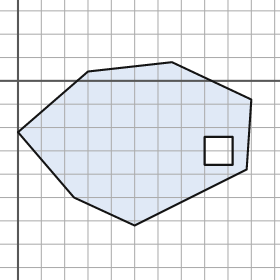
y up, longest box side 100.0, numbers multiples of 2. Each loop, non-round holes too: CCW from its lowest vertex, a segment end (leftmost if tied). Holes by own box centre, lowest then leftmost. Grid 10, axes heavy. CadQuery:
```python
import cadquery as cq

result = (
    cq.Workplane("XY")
    .moveTo(50.0, -62.0)
    .lineTo(98.0, -38.0)
    .lineTo(100.0, -8.0)
    .lineTo(66.0, 8.0)
    .lineTo(30.0, 4.0)
    .lineTo(0.0, -22.0)
    .lineTo(24.0, -50.0)
    .close()
    .moveTo(80.0, -36.0)
    .lineTo(92.0, -36.0)
    .lineTo(92.0, -24.0)
    .lineTo(80.0, -24.0)
    .close()
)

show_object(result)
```